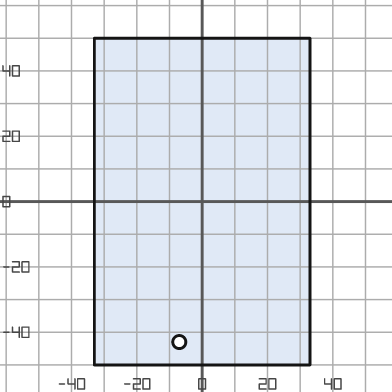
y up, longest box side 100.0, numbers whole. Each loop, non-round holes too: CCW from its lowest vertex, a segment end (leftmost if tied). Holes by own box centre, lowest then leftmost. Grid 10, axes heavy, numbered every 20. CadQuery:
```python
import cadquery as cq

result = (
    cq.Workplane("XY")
    .moveTo(-33.0, -50.0)
    .lineTo(33.0, -50.0)
    .lineTo(33.0, 50.0)
    .lineTo(-33.0, 50.0)
    .close()
    .moveTo(-7.0, -43.0)
    .circle(2.0)
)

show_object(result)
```